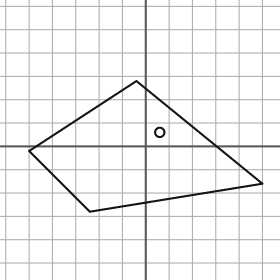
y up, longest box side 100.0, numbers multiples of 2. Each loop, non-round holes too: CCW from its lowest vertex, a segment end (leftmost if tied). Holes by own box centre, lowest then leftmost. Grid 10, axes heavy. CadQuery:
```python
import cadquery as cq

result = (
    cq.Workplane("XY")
    .moveTo(-24.0, -28.0)
    .lineTo(50.0, -16.0)
    .lineTo(-4.0, 28.0)
    .lineTo(-50.0, -2.0)
    .close()
    .moveTo(6.0, 6.0)
    .circle(2.0)
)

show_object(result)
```